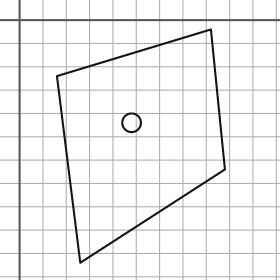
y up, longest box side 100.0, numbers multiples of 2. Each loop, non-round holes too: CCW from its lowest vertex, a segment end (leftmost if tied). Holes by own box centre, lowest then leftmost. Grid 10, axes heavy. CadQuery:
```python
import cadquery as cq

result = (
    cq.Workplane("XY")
    .moveTo(26.0, -104.0)
    .lineTo(88.0, -64.0)
    .lineTo(82.0, -4.0)
    .lineTo(16.0, -24.0)
    .close()
    .moveTo(48.0, -44.0)
    .circle(4.0)
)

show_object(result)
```